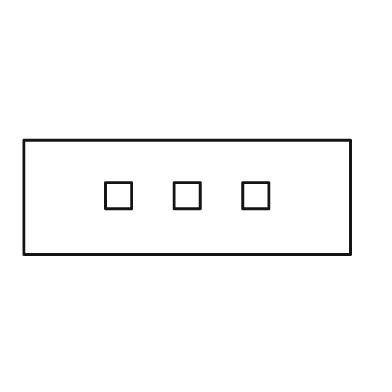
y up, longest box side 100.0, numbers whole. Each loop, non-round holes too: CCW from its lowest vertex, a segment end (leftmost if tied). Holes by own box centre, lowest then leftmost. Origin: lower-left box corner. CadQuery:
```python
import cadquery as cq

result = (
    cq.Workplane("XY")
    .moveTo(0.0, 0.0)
    .lineTo(100.0, 0.0)
    .lineTo(100.0, 35.0)
    .lineTo(0.0, 35.0)
    .close()
    .moveTo(25.0, 14.0)
    .lineTo(33.0, 14.0)
    .lineTo(33.0, 22.0)
    .lineTo(25.0, 22.0)
    .close()
    .moveTo(46.0, 14.0)
    .lineTo(54.0, 14.0)
    .lineTo(54.0, 22.0)
    .lineTo(46.0, 22.0)
    .close()
    .moveTo(67.0, 14.0)
    .lineTo(75.0, 14.0)
    .lineTo(75.0, 22.0)
    .lineTo(67.0, 22.0)
    .close()
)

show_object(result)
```